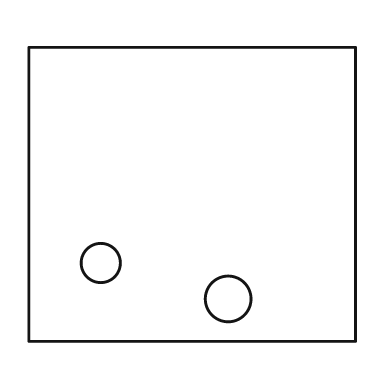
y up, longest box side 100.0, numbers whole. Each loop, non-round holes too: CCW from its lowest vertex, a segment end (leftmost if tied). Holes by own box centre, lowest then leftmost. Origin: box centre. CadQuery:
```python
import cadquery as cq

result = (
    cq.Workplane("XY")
    .moveTo(-50.0, -45.0)
    .lineTo(50.0, -45.0)
    .lineTo(50.0, 45.0)
    .lineTo(-50.0, 45.0)
    .close()
    .moveTo(11.0, -32.0)
    .circle(7.0)
    .moveTo(-28.0, -21.0)
    .circle(6.0)
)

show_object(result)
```